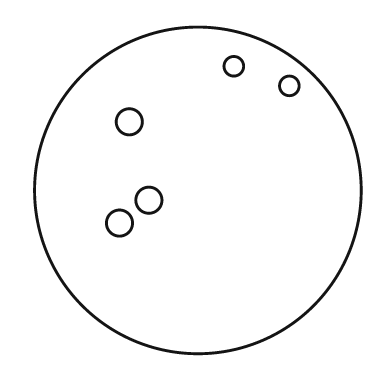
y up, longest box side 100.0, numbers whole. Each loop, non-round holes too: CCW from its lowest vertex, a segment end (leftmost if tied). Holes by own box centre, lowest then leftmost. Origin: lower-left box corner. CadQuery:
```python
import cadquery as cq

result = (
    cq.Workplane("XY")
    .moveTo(50.0, 50.0)
    .circle(50.0)
    .moveTo(26.0, 40.0)
    .circle(4.0)
    .moveTo(35.0, 47.0)
    .circle(4.0)
    .moveTo(29.0, 71.0)
    .circle(4.0)
    .moveTo(78.0, 82.0)
    .circle(3.0)
    .moveTo(61.0, 88.0)
    .circle(3.0)
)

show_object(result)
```